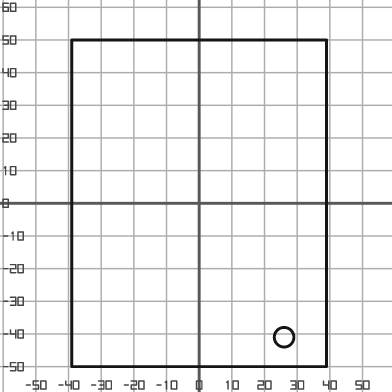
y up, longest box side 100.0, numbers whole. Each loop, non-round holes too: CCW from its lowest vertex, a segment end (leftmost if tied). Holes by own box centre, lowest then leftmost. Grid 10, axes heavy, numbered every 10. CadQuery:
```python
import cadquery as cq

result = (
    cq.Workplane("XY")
    .moveTo(-39.0, -50.0)
    .lineTo(39.0, -50.0)
    .lineTo(39.0, 50.0)
    .lineTo(-39.0, 50.0)
    .close()
    .moveTo(26.0, -41.0)
    .circle(3.0)
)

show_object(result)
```